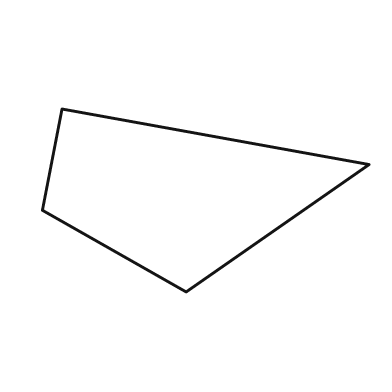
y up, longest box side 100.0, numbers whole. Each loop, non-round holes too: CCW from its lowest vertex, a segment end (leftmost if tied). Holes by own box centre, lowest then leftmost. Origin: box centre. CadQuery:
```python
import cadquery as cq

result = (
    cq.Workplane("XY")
    .moveTo(-6.0, -28.0)
    .lineTo(50.0, 11.0)
    .lineTo(-44.0, 28.0)
    .lineTo(-50.0, -3.0)
    .close()
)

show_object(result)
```